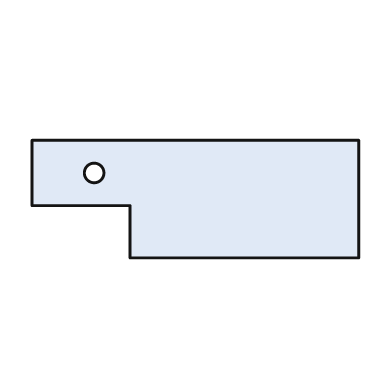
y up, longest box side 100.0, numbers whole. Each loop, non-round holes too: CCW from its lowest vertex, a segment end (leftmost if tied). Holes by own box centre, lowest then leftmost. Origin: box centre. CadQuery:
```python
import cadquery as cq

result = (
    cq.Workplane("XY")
    .moveTo(-20.0, -18.0)
    .lineTo(50.0, -18.0)
    .lineTo(50.0, 18.0)
    .lineTo(-50.0, 18.0)
    .lineTo(-50.0, -2.0)
    .lineTo(-20.0, -2.0)
    .close()
    .moveTo(-31.0, 8.0)
    .circle(3.0)
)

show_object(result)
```